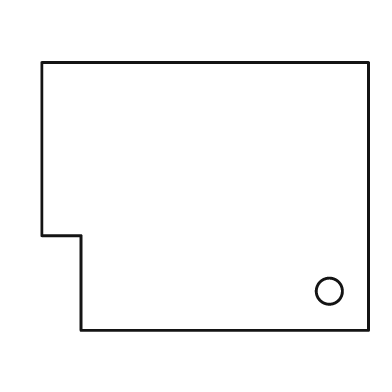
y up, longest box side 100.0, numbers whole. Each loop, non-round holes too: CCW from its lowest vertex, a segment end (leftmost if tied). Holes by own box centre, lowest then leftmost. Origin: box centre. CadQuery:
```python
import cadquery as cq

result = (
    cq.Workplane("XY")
    .moveTo(-38.0, -41.0)
    .lineTo(50.0, -41.0)
    .lineTo(50.0, 41.0)
    .lineTo(-50.0, 41.0)
    .lineTo(-50.0, -12.0)
    .lineTo(-38.0, -12.0)
    .close()
    .moveTo(38.0, -29.0)
    .circle(4.0)
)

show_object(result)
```